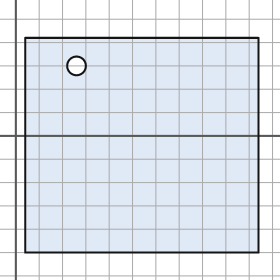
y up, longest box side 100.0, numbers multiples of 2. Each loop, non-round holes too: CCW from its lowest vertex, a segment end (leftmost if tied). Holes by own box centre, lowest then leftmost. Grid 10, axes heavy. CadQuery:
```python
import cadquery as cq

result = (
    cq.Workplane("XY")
    .moveTo(4.0, -50.0)
    .lineTo(104.0, -50.0)
    .lineTo(104.0, 42.0)
    .lineTo(4.0, 42.0)
    .close()
    .moveTo(26.0, 30.0)
    .circle(4.0)
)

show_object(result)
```